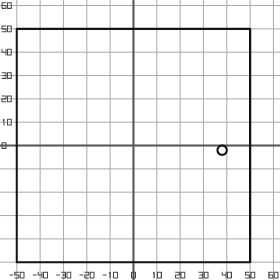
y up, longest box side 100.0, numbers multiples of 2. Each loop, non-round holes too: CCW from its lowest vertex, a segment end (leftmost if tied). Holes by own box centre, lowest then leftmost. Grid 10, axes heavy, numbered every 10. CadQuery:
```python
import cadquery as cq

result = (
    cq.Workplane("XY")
    .moveTo(-50.0, -50.0)
    .lineTo(50.0, -50.0)
    .lineTo(50.0, 50.0)
    .lineTo(-50.0, 50.0)
    .close()
    .moveTo(38.0, -2.0)
    .circle(2.0)
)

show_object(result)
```